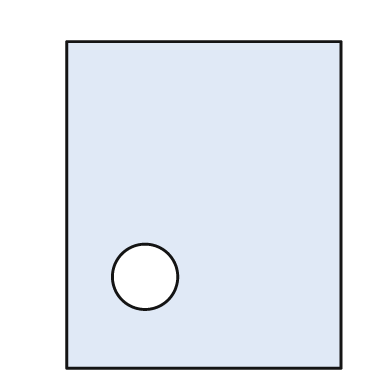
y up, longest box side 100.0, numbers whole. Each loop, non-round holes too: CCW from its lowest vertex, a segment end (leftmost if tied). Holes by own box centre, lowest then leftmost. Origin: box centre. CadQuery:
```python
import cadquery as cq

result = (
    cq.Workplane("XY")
    .moveTo(-42.0, -50.0)
    .lineTo(42.0, -50.0)
    .lineTo(42.0, 50.0)
    .lineTo(-42.0, 50.0)
    .close()
    .moveTo(-18.0, -22.0)
    .circle(10.0)
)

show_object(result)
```